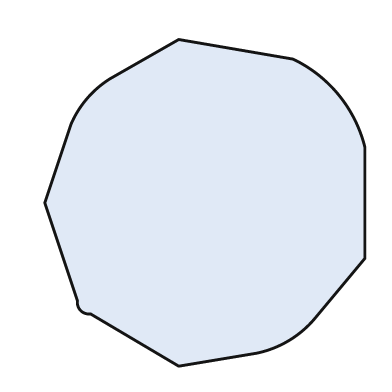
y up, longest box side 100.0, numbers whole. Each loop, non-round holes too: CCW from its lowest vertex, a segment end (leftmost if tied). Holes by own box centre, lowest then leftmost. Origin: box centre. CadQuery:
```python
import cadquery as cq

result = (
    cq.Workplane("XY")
    .moveTo(-8.0, -50.0)
    .lineTo(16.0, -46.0)
    .threePointArc((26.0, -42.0), (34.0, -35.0))
    .lineTo(49.0, -17.0)
    .lineTo(49.0, 17.0)
    .threePointArc((41.0, 33.0), (27.0, 44.0))
    .lineTo(-8.0, 50.0)
    .lineTo(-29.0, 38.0)
    .threePointArc((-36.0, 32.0), (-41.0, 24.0))
    .lineTo(-49.0, 0.0)
    .lineTo(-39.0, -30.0)
    .threePointArc((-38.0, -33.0), (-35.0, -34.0))
    .close()
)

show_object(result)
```